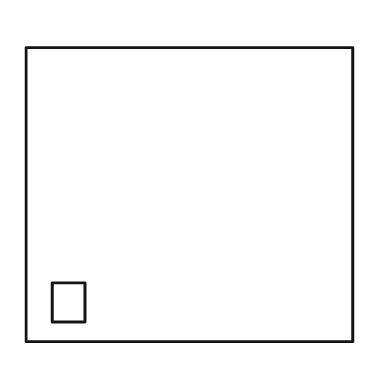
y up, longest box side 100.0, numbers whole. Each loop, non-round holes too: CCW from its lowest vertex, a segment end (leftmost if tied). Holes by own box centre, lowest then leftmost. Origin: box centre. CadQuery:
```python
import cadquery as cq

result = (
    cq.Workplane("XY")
    .moveTo(-50.0, -45.0)
    .lineTo(50.0, -45.0)
    .lineTo(50.0, 45.0)
    .lineTo(-50.0, 45.0)
    .close()
    .moveTo(-42.0, -39.0)
    .lineTo(-32.0, -39.0)
    .lineTo(-32.0, -27.0)
    .lineTo(-42.0, -27.0)
    .close()
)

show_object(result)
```